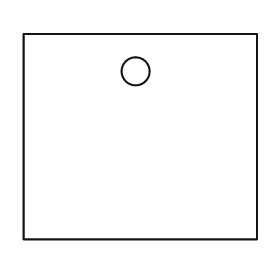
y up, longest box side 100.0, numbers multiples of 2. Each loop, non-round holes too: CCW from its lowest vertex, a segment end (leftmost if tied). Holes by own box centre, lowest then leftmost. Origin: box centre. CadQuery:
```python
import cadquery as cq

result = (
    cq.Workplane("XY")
    .moveTo(-50.0, -44.0)
    .lineTo(50.0, -44.0)
    .lineTo(50.0, 44.0)
    .lineTo(-50.0, 44.0)
    .close()
    .moveTo(-2.0, 28.0)
    .circle(6.0)
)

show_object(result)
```